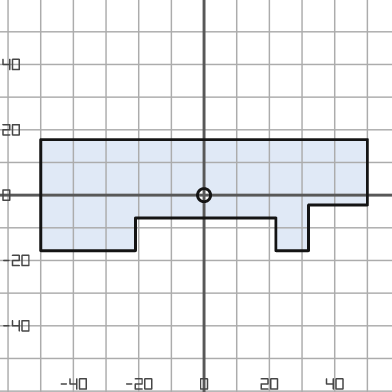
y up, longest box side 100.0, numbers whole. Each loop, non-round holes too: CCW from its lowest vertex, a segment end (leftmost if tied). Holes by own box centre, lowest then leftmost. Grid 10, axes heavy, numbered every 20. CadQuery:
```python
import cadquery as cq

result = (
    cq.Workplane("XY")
    .moveTo(-50.0, -17.0)
    .lineTo(-21.0, -17.0)
    .lineTo(-21.0, -7.0)
    .lineTo(22.0, -7.0)
    .lineTo(22.0, -17.0)
    .lineTo(32.0, -17.0)
    .lineTo(32.0, -3.0)
    .lineTo(50.0, -3.0)
    .lineTo(50.0, 17.0)
    .lineTo(-50.0, 17.0)
    .close()
    .moveTo(0.0, 0.0)
    .circle(2.0)
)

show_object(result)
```